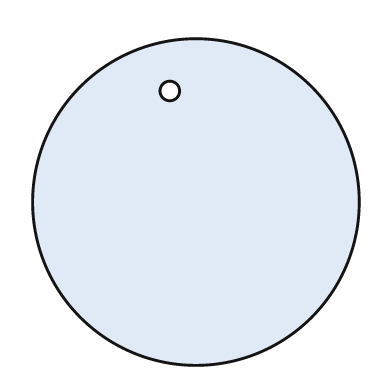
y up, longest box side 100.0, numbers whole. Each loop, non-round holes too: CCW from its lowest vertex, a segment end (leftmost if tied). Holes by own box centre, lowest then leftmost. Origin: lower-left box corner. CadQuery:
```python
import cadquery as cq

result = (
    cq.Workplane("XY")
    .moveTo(50.0, 50.0)
    .circle(50.0)
    .moveTo(42.0, 84.0)
    .circle(3.0)
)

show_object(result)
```